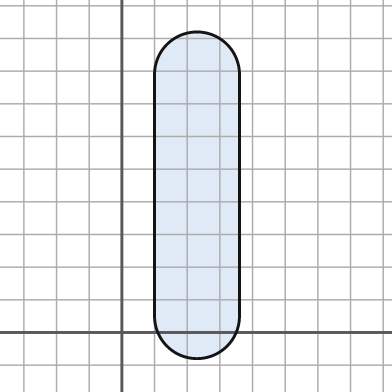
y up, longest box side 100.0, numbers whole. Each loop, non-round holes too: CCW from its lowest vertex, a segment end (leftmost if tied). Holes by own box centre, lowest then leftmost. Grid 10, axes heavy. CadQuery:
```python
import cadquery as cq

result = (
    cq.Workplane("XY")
    .moveTo(10.0, 5.0)
    .threePointArc((23.0, -8.0), (36.0, 5.0))
    .lineTo(36.0, 79.0)
    .threePointArc((23.0, 92.0), (10.0, 79.0))
    .close()
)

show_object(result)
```